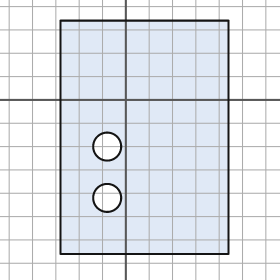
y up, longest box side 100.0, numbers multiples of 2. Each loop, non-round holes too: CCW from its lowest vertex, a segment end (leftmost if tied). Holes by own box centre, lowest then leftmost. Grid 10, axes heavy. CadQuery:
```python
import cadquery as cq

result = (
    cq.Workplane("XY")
    .moveTo(-28.0, -66.0)
    .lineTo(44.0, -66.0)
    .lineTo(44.0, 34.0)
    .lineTo(-28.0, 34.0)
    .close()
    .moveTo(-8.0, -42.0)
    .circle(6.0)
    .moveTo(-8.0, -20.0)
    .circle(6.0)
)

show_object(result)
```